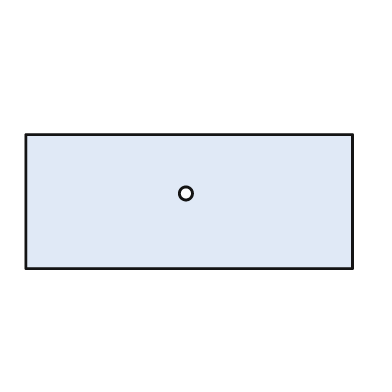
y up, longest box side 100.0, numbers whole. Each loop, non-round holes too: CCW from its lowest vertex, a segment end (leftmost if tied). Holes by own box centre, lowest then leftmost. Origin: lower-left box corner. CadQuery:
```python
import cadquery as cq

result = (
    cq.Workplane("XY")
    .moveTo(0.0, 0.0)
    .lineTo(100.0, 0.0)
    .lineTo(100.0, 41.0)
    .lineTo(0.0, 41.0)
    .close()
    .moveTo(49.0, 23.0)
    .circle(2.0)
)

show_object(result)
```